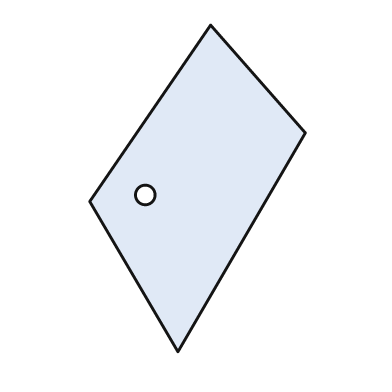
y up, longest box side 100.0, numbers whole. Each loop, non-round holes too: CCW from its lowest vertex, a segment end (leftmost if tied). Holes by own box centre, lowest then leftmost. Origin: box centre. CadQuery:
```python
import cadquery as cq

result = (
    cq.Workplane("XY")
    .moveTo(-6.0, -50.0)
    .lineTo(33.0, 17.0)
    .lineTo(4.0, 50.0)
    .lineTo(-33.0, -4.0)
    .close()
    .moveTo(-16.0, -2.0)
    .circle(3.0)
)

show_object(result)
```